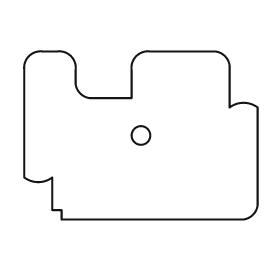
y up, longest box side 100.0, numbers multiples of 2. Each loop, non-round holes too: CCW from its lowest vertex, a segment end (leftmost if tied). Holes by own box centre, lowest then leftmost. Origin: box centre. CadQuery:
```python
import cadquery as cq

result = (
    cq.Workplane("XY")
    .moveTo(-34.0, -36.0)
    .lineTo(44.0, -36.0)
    .threePointArc((48.0, -34.0), (50.0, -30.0))
    .lineTo(50.0, 12.0)
    .threePointArc((44.0, 14.0), (38.0, 12.0))
    .lineTo(38.0, 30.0)
    .threePointArc((36.0, 34.0), (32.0, 36.0))
    .lineTo(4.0, 36.0)
    .threePointArc((-2.0, 34.0), (-4.0, 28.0))
    .lineTo(-4.0, 16.0)
    .lineTo(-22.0, 16.0)
    .threePointArc((-26.0, 18.0), (-28.0, 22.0))
    .lineTo(-28.0, 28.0)
    .threePointArc((-30.0, 34.0), (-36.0, 36.0))
    .lineTo(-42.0, 36.0)
    .threePointArc((-48.0, 34.0), (-50.0, 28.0))
    .lineTo(-50.0, -18.0)
    .threePointArc((-44.0, -20.0), (-38.0, -18.0))
    .lineTo(-38.0, -32.0)
    .lineTo(-34.0, -32.0)
    .close()
    .moveTo(0.0, 0.0)
    .circle(4.0)
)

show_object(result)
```